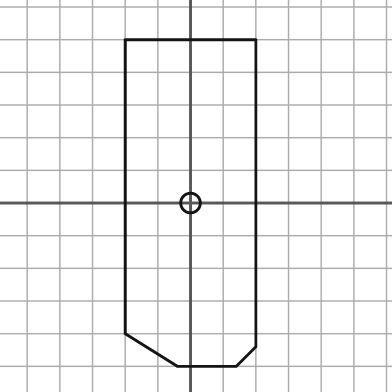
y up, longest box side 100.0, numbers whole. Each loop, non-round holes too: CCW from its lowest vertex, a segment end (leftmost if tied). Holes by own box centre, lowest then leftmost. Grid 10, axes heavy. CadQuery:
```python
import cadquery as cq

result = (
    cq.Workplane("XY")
    .moveTo(-4.0, -50.0)
    .lineTo(14.0, -50.0)
    .lineTo(20.0, -44.0)
    .lineTo(20.0, 50.0)
    .lineTo(-20.0, 50.0)
    .lineTo(-20.0, -40.0)
    .close()
    .moveTo(0.0, 0.0)
    .circle(3.0)
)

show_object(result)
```